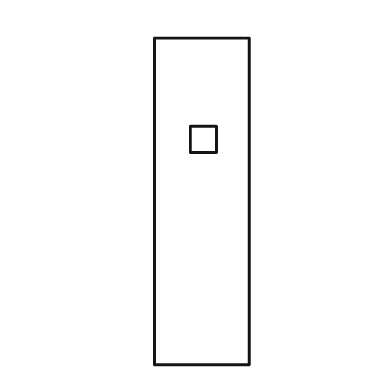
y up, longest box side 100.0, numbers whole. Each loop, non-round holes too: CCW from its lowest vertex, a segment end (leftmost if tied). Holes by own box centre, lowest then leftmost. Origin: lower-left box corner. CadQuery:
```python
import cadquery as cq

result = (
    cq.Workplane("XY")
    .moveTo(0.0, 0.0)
    .lineTo(29.0, 0.0)
    .lineTo(29.0, 100.0)
    .lineTo(0.0, 100.0)
    .close()
    .moveTo(11.0, 65.0)
    .lineTo(19.0, 65.0)
    .lineTo(19.0, 73.0)
    .lineTo(11.0, 73.0)
    .close()
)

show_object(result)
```